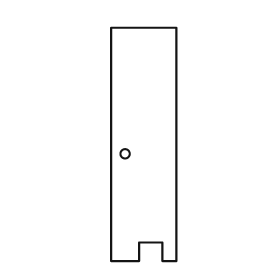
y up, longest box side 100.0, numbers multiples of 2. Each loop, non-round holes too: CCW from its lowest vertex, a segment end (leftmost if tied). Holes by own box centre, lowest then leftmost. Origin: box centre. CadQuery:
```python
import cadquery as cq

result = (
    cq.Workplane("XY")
    .moveTo(-14.0, -50.0)
    .lineTo(-2.0, -50.0)
    .lineTo(-2.0, -42.0)
    .lineTo(8.0, -42.0)
    .lineTo(8.0, -50.0)
    .lineTo(14.0, -50.0)
    .lineTo(14.0, 50.0)
    .lineTo(-14.0, 50.0)
    .close()
    .moveTo(-8.0, -4.0)
    .circle(2.0)
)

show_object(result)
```